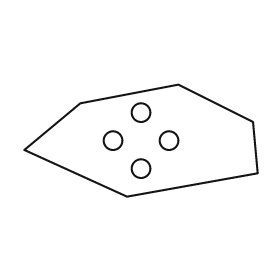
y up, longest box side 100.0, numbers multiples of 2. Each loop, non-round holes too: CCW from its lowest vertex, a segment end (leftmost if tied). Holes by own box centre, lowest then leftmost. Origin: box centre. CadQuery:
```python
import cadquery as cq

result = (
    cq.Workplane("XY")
    .moveTo(-6.0, -24.0)
    .lineTo(50.0, -14.0)
    .lineTo(48.0, 8.0)
    .lineTo(16.0, 24.0)
    .lineTo(-26.0, 16.0)
    .lineTo(-50.0, -4.0)
    .close()
    .moveTo(0.0, -12.0)
    .circle(4.0)
    .moveTo(-12.0, 0.0)
    .circle(4.0)
    .moveTo(12.0, 0.0)
    .circle(4.0)
    .moveTo(0.0, 12.0)
    .circle(4.0)
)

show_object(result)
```